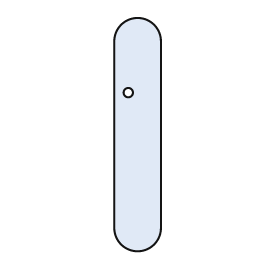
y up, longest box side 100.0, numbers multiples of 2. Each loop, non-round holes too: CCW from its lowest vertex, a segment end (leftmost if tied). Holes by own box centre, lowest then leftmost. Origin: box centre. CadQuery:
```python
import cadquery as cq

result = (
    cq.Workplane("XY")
    .moveTo(-10.0, -40.0)
    .threePointArc((0.0, -50.0), (10.0, -40.0))
    .lineTo(10.0, 40.0)
    .threePointArc((0.0, 50.0), (-10.0, 40.0))
    .close()
    .moveTo(-4.0, 18.0)
    .circle(2.0)
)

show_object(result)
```